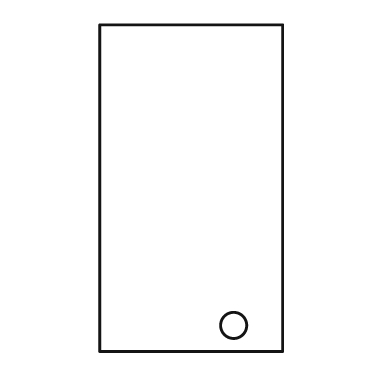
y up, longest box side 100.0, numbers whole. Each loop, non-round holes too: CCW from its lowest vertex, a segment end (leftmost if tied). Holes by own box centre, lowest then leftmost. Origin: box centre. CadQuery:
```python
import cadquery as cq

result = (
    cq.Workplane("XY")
    .moveTo(-28.0, -50.0)
    .lineTo(28.0, -50.0)
    .lineTo(28.0, 50.0)
    .lineTo(-28.0, 50.0)
    .close()
    .moveTo(13.0, -42.0)
    .circle(4.0)
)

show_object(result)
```